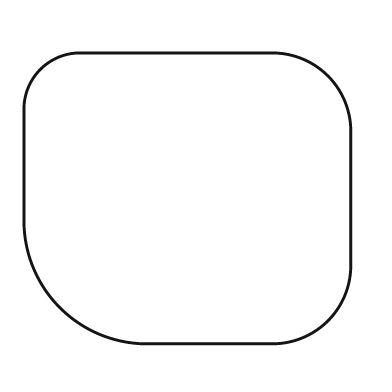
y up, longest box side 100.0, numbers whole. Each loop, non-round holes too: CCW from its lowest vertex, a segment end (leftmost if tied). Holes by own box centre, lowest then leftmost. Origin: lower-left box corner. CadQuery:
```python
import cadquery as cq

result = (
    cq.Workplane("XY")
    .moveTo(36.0, 0.0)
    .lineTo(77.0, 0.0)
    .threePointArc((93.0, 7.0), (100.0, 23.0))
    .lineTo(100.0, 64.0)
    .threePointArc((93.0, 82.0), (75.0, 89.0))
    .lineTo(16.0, 89.0)
    .threePointArc((5.0, 84.0), (0.0, 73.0))
    .lineTo(0.0, 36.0)
    .threePointArc((11.0, 11.0), (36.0, 0.0))
    .close()
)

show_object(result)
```